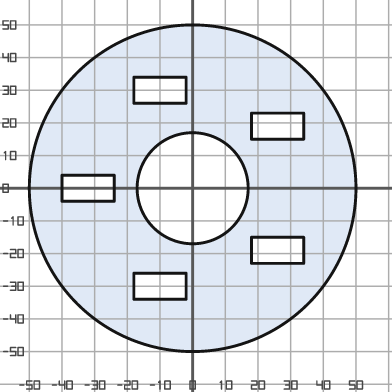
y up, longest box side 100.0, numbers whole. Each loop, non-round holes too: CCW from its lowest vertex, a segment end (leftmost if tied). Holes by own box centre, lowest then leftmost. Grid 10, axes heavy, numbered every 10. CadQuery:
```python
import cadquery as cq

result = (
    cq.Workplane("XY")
    .moveTo(0.0, 0.0)
    .circle(50.0)
    .moveTo(-18.0, -34.0)
    .lineTo(-2.0, -34.0)
    .lineTo(-2.0, -26.0)
    .lineTo(-18.0, -26.0)
    .close()
    .moveTo(18.0, -23.0)
    .lineTo(34.0, -23.0)
    .lineTo(34.0, -15.0)
    .lineTo(18.0, -15.0)
    .close()
    .moveTo(-40.0, -4.0)
    .lineTo(-24.0, -4.0)
    .lineTo(-24.0, 4.0)
    .lineTo(-40.0, 4.0)
    .close()
    .moveTo(0.0, 0.0)
    .circle(17.0)
    .moveTo(18.0, 15.0)
    .lineTo(34.0, 15.0)
    .lineTo(34.0, 23.0)
    .lineTo(18.0, 23.0)
    .close()
    .moveTo(-18.0, 26.0)
    .lineTo(-2.0, 26.0)
    .lineTo(-2.0, 34.0)
    .lineTo(-18.0, 34.0)
    .close()
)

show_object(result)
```